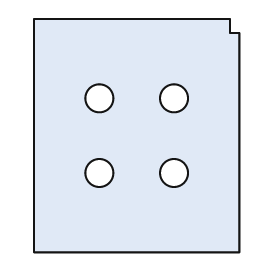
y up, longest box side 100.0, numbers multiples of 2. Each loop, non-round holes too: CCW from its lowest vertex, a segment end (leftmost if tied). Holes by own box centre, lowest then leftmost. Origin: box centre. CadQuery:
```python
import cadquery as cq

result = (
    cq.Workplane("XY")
    .moveTo(-44.0, -50.0)
    .lineTo(44.0, -50.0)
    .lineTo(44.0, 44.0)
    .lineTo(40.0, 44.0)
    .lineTo(40.0, 50.0)
    .lineTo(-44.0, 50.0)
    .close()
    .moveTo(-16.0, -16.0)
    .circle(6.0)
    .moveTo(16.0, -16.0)
    .circle(6.0)
    .moveTo(-16.0, 16.0)
    .circle(6.0)
    .moveTo(16.0, 16.0)
    .circle(6.0)
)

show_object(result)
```